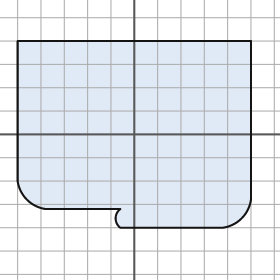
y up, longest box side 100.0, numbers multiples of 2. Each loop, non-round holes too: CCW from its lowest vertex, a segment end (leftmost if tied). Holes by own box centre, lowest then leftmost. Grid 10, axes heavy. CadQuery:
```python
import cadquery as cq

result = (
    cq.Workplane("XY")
    .moveTo(-6.0, -40.0)
    .lineTo(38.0, -40.0)
    .threePointArc((46.0, -36.0), (50.0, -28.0))
    .lineTo(50.0, 40.0)
    .lineTo(-50.0, 40.0)
    .lineTo(-50.0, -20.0)
    .threePointArc((-46.0, -28.0), (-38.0, -32.0))
    .lineTo(-6.0, -32.0)
    .threePointArc((-8.0, -36.0), (-6.0, -40.0))
    .close()
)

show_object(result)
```